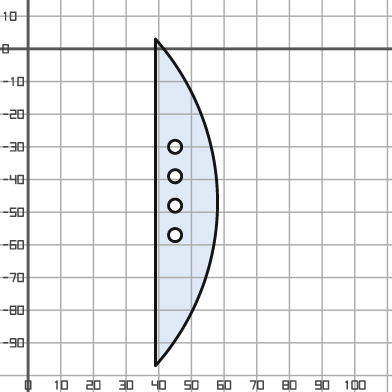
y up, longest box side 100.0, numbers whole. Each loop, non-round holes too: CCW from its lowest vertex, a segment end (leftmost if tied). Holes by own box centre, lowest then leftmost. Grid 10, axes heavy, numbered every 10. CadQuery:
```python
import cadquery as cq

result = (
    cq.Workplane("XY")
    .moveTo(39.0, -97.0)
    .threePointArc((58.0, -47.0), (39.0, 3.0))
    .close()
    .moveTo(45.0, -57.0)
    .circle(2.0)
    .moveTo(45.0, -48.0)
    .circle(2.0)
    .moveTo(45.0, -39.0)
    .circle(2.0)
    .moveTo(45.0, -30.0)
    .circle(2.0)
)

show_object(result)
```